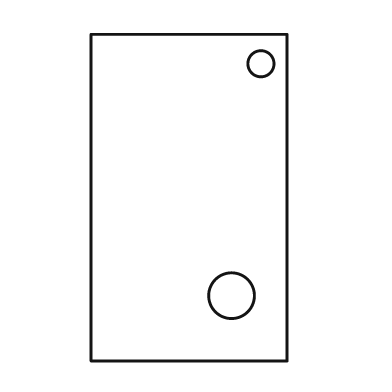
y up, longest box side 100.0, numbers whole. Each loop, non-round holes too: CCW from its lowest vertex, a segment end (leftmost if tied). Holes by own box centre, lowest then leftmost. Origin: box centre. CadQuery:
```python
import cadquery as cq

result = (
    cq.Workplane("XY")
    .moveTo(-30.0, -50.0)
    .lineTo(30.0, -50.0)
    .lineTo(30.0, 50.0)
    .lineTo(-30.0, 50.0)
    .close()
    .moveTo(13.0, -30.0)
    .circle(7.0)
    .moveTo(22.0, 41.0)
    .circle(4.0)
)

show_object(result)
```